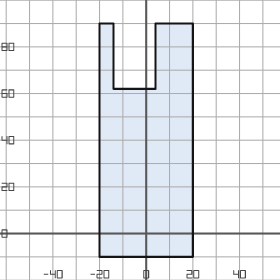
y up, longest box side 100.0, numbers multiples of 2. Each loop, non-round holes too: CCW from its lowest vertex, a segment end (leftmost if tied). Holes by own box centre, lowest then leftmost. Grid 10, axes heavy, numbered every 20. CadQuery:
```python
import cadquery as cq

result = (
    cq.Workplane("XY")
    .moveTo(-20.0, -10.0)
    .lineTo(20.0, -10.0)
    .lineTo(20.0, 90.0)
    .lineTo(4.0, 90.0)
    .lineTo(4.0, 62.0)
    .lineTo(-14.0, 62.0)
    .lineTo(-14.0, 90.0)
    .lineTo(-20.0, 90.0)
    .close()
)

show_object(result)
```